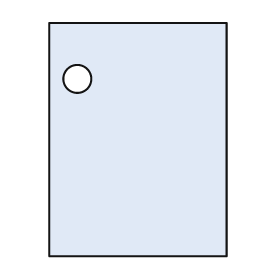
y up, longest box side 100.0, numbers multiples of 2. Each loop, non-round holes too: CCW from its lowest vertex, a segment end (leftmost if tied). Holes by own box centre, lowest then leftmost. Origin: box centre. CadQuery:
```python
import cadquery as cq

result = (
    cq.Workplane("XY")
    .moveTo(-38.0, -50.0)
    .lineTo(38.0, -50.0)
    .lineTo(38.0, 50.0)
    .lineTo(-38.0, 50.0)
    .close()
    .moveTo(-26.0, 26.0)
    .circle(6.0)
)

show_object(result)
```